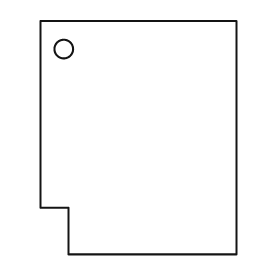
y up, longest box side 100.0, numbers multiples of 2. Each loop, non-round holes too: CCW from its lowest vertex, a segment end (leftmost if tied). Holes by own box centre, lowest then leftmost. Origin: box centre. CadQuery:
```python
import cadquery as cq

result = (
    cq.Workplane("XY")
    .moveTo(-30.0, -50.0)
    .lineTo(42.0, -50.0)
    .lineTo(42.0, 50.0)
    .lineTo(-42.0, 50.0)
    .lineTo(-42.0, -30.0)
    .lineTo(-30.0, -30.0)
    .close()
    .moveTo(-32.0, 38.0)
    .circle(4.0)
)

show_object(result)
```